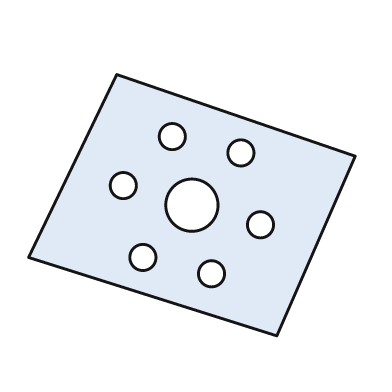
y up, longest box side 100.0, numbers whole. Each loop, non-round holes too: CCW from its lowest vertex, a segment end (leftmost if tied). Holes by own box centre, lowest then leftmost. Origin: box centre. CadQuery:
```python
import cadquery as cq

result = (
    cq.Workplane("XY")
    .moveTo(26.0, -40.0)
    .lineTo(50.0, 15.0)
    .lineTo(-23.0, 40.0)
    .lineTo(-50.0, -16.0)
    .close()
    .moveTo(6.0, -21.0)
    .circle(4.0)
    .moveTo(-15.0, -16.0)
    .circle(4.0)
    .moveTo(21.0, -6.0)
    .circle(4.0)
    .moveTo(0.0, 0.0)
    .circle(8.0)
    .moveTo(-21.0, 6.0)
    .circle(4.0)
    .moveTo(15.0, 16.0)
    .circle(4.0)
    .moveTo(-6.0, 21.0)
    .circle(4.0)
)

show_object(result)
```